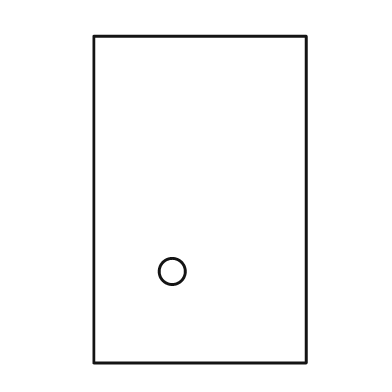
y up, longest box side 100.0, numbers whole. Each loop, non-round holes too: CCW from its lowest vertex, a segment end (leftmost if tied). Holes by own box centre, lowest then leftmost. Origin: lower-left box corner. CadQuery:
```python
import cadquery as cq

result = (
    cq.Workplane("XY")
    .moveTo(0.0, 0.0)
    .lineTo(65.0, 0.0)
    .lineTo(65.0, 100.0)
    .lineTo(0.0, 100.0)
    .close()
    .moveTo(24.0, 28.0)
    .circle(4.0)
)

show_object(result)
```